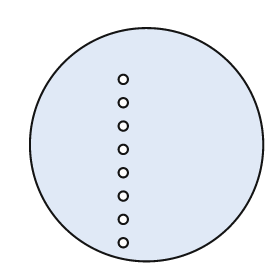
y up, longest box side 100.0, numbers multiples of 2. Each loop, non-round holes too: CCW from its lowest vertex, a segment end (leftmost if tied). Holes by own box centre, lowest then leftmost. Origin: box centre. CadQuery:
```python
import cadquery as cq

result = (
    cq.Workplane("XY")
    .moveTo(0.0, 0.0)
    .circle(50.0)
    .moveTo(-10.0, -42.0)
    .circle(2.0)
    .moveTo(-10.0, -32.0)
    .circle(2.0)
    .moveTo(-10.0, -22.0)
    .circle(2.0)
    .moveTo(-10.0, -12.0)
    .circle(2.0)
    .moveTo(-10.0, -2.0)
    .circle(2.0)
    .moveTo(-10.0, 8.0)
    .circle(2.0)
    .moveTo(-10.0, 18.0)
    .circle(2.0)
    .moveTo(-10.0, 28.0)
    .circle(2.0)
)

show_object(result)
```